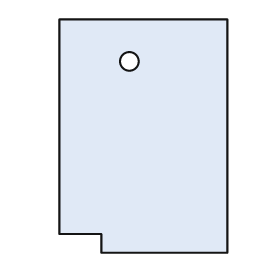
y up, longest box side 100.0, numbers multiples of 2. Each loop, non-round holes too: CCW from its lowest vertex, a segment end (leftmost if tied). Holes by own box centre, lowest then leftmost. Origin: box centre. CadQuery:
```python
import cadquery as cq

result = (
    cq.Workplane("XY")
    .moveTo(-18.0, -50.0)
    .lineTo(36.0, -50.0)
    .lineTo(36.0, 50.0)
    .lineTo(-36.0, 50.0)
    .lineTo(-36.0, -42.0)
    .lineTo(-18.0, -42.0)
    .close()
    .moveTo(-6.0, 32.0)
    .circle(4.0)
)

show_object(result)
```